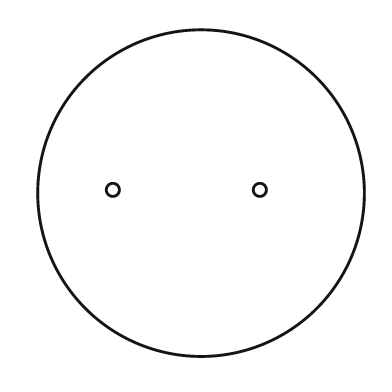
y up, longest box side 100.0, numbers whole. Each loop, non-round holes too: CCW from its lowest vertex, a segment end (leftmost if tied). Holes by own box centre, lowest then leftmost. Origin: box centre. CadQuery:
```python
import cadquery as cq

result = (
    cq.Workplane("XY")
    .moveTo(0.0, 0.0)
    .circle(50.0)
    .moveTo(-27.0, 1.0)
    .circle(2.0)
    .moveTo(18.0, 1.0)
    .circle(2.0)
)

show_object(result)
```